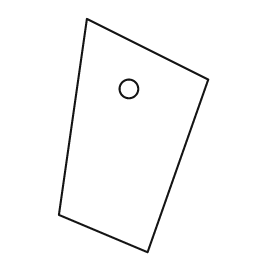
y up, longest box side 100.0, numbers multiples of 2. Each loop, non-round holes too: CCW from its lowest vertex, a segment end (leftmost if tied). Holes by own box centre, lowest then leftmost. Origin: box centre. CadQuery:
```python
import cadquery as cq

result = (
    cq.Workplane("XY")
    .moveTo(6.0, -50.0)
    .lineTo(32.0, 24.0)
    .lineTo(-20.0, 50.0)
    .lineTo(-32.0, -34.0)
    .close()
    .moveTo(-2.0, 20.0)
    .circle(4.0)
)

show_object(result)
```